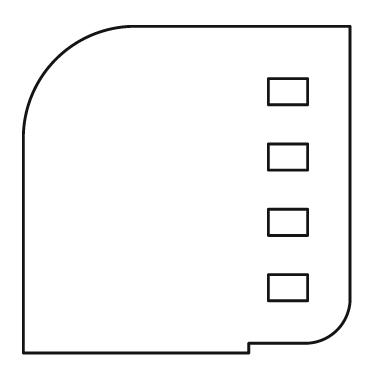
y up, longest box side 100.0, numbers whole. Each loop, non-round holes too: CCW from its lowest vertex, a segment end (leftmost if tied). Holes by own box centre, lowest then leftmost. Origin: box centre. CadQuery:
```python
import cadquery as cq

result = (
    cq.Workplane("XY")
    .moveTo(-50.0, -50.0)
    .lineTo(19.0, -50.0)
    .lineTo(19.0, -47.0)
    .lineTo(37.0, -47.0)
    .threePointArc((46.0, -43.0), (50.0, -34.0))
    .lineTo(50.0, 50.0)
    .lineTo(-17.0, 50.0)
    .threePointArc((-40.0, 40.0), (-50.0, 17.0))
    .close()
    .moveTo(25.0, -34.0)
    .lineTo(37.0, -34.0)
    .lineTo(37.0, -26.0)
    .lineTo(25.0, -26.0)
    .close()
    .moveTo(25.0, -14.0)
    .lineTo(37.0, -14.0)
    .lineTo(37.0, -6.0)
    .lineTo(25.0, -6.0)
    .close()
    .moveTo(25.0, 6.0)
    .lineTo(37.0, 6.0)
    .lineTo(37.0, 14.0)
    .lineTo(25.0, 14.0)
    .close()
    .moveTo(25.0, 26.0)
    .lineTo(37.0, 26.0)
    .lineTo(37.0, 34.0)
    .lineTo(25.0, 34.0)
    .close()
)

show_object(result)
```